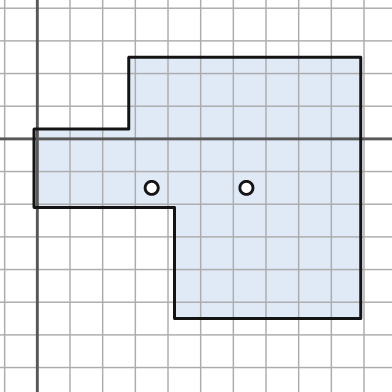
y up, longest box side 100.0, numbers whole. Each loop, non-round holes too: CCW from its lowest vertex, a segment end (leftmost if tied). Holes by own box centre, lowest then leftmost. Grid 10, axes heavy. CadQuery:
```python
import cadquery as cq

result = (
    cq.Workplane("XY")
    .moveTo(42.0, -55.0)
    .lineTo(99.0, -55.0)
    .lineTo(99.0, 25.0)
    .lineTo(28.0, 25.0)
    .lineTo(28.0, 3.0)
    .lineTo(-1.0, 3.0)
    .lineTo(-1.0, -21.0)
    .lineTo(42.0, -21.0)
    .close()
    .moveTo(35.0, -15.0)
    .circle(2.0)
    .moveTo(64.0, -15.0)
    .circle(2.0)
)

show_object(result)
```